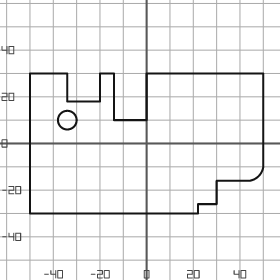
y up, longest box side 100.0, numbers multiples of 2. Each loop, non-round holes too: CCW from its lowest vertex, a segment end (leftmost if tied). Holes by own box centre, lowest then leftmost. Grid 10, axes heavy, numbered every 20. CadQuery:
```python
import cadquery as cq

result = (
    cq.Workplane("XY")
    .moveTo(-50.0, -30.0)
    .lineTo(22.0, -30.0)
    .lineTo(22.0, -26.0)
    .lineTo(30.0, -26.0)
    .lineTo(30.0, -16.0)
    .lineTo(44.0, -16.0)
    .threePointArc((48.0, -14.0), (50.0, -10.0))
    .lineTo(50.0, 30.0)
    .lineTo(0.0, 30.0)
    .lineTo(0.0, 10.0)
    .lineTo(-14.0, 10.0)
    .lineTo(-14.0, 30.0)
    .lineTo(-20.0, 30.0)
    .lineTo(-20.0, 18.0)
    .lineTo(-34.0, 18.0)
    .lineTo(-34.0, 30.0)
    .lineTo(-50.0, 30.0)
    .close()
    .moveTo(-34.0, 10.0)
    .circle(4.0)
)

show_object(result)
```